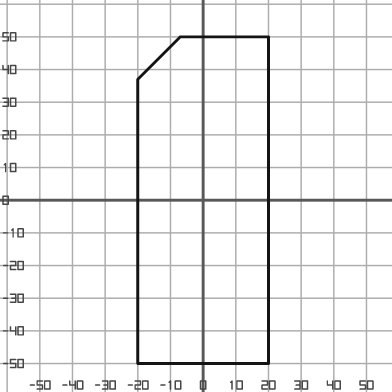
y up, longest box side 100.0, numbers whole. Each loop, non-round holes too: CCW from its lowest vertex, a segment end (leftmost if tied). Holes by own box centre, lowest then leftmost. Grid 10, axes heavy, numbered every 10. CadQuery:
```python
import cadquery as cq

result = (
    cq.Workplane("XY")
    .moveTo(-20.0, -50.0)
    .lineTo(20.0, -50.0)
    .lineTo(20.0, 50.0)
    .lineTo(-7.0, 50.0)
    .lineTo(-20.0, 37.0)
    .close()
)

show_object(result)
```